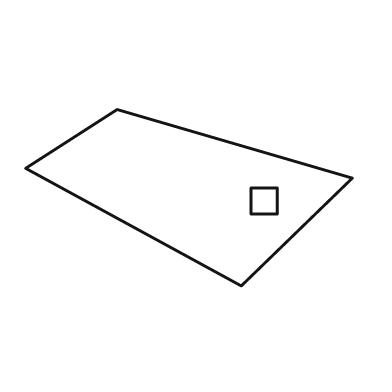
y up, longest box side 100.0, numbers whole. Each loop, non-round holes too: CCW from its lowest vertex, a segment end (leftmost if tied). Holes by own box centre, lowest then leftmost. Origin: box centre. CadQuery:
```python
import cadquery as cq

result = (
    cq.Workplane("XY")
    .moveTo(16.0, -27.0)
    .lineTo(50.0, 6.0)
    .lineTo(-22.0, 27.0)
    .lineTo(-50.0, 9.0)
    .close()
    .moveTo(19.0, -5.0)
    .lineTo(27.0, -5.0)
    .lineTo(27.0, 3.0)
    .lineTo(19.0, 3.0)
    .close()
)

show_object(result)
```